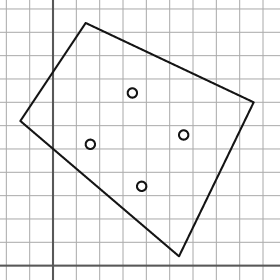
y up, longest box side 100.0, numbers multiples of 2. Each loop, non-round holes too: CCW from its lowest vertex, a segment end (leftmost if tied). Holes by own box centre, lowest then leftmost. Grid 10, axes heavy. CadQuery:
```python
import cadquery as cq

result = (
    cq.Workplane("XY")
    .moveTo(54.0, 4.0)
    .lineTo(86.0, 70.0)
    .lineTo(14.0, 104.0)
    .lineTo(-14.0, 62.0)
    .close()
    .moveTo(38.0, 34.0)
    .circle(2.0)
    .moveTo(16.0, 52.0)
    .circle(2.0)
    .moveTo(56.0, 56.0)
    .circle(2.0)
    .moveTo(34.0, 74.0)
    .circle(2.0)
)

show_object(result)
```